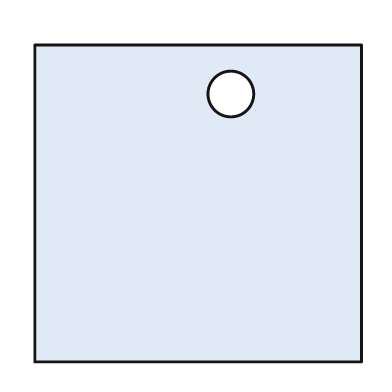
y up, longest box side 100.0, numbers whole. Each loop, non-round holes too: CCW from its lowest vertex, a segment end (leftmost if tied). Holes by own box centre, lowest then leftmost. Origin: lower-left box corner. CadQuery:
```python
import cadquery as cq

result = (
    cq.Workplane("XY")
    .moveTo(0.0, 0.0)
    .lineTo(100.0, 0.0)
    .lineTo(100.0, 97.0)
    .lineTo(0.0, 97.0)
    .close()
    .moveTo(60.0, 82.0)
    .circle(7.0)
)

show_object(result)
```